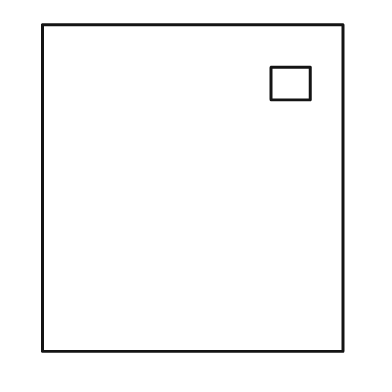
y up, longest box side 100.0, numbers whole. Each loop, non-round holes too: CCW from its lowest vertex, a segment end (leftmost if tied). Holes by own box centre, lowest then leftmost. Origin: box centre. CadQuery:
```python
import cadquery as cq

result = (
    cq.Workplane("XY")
    .moveTo(-46.0, -50.0)
    .lineTo(46.0, -50.0)
    .lineTo(46.0, 50.0)
    .lineTo(-46.0, 50.0)
    .close()
    .moveTo(24.0, 27.0)
    .lineTo(36.0, 27.0)
    .lineTo(36.0, 37.0)
    .lineTo(24.0, 37.0)
    .close()
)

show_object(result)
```